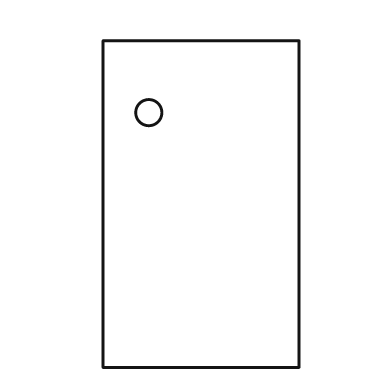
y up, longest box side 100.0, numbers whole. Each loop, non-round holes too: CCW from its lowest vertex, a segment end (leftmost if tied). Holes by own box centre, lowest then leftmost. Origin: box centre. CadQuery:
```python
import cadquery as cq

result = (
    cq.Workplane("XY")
    .moveTo(-30.0, -50.0)
    .lineTo(30.0, -50.0)
    .lineTo(30.0, 50.0)
    .lineTo(-30.0, 50.0)
    .close()
    .moveTo(-16.0, 28.0)
    .circle(4.0)
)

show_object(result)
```